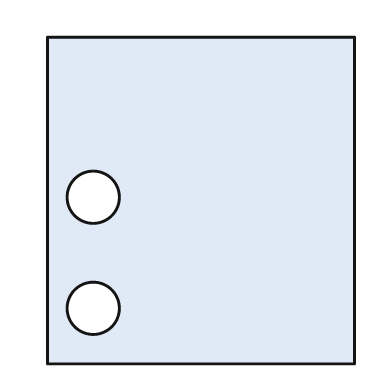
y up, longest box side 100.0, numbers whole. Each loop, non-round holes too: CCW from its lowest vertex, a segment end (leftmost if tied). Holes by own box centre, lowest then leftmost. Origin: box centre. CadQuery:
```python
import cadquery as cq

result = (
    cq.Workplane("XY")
    .moveTo(-47.0, -50.0)
    .lineTo(47.0, -50.0)
    .lineTo(47.0, 50.0)
    .lineTo(-47.0, 50.0)
    .close()
    .moveTo(-33.0, -33.0)
    .circle(8.0)
    .moveTo(-33.0, 1.0)
    .circle(8.0)
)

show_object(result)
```